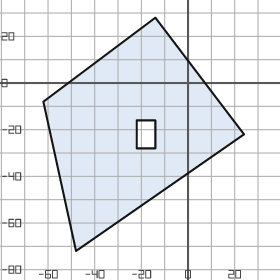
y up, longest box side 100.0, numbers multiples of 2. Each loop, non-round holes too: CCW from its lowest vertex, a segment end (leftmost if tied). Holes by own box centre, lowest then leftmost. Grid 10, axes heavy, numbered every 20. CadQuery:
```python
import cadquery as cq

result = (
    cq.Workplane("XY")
    .moveTo(-48.0, -72.0)
    .lineTo(24.0, -22.0)
    .lineTo(-14.0, 28.0)
    .lineTo(-62.0, -8.0)
    .close()
    .moveTo(-22.0, -28.0)
    .lineTo(-14.0, -28.0)
    .lineTo(-14.0, -16.0)
    .lineTo(-22.0, -16.0)
    .close()
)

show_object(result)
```